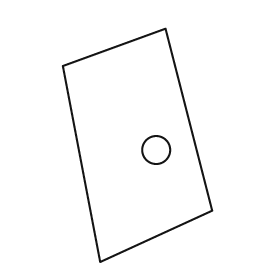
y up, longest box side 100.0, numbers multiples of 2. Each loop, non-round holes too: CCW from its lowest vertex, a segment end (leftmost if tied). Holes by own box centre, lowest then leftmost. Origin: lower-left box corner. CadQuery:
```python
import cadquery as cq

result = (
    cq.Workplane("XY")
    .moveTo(16.0, 0.0)
    .lineTo(64.0, 22.0)
    .lineTo(44.0, 100.0)
    .lineTo(0.0, 84.0)
    .close()
    .moveTo(40.0, 48.0)
    .circle(6.0)
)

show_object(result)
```